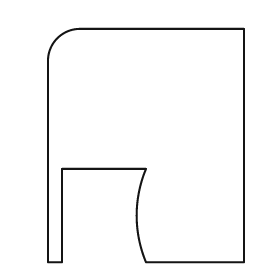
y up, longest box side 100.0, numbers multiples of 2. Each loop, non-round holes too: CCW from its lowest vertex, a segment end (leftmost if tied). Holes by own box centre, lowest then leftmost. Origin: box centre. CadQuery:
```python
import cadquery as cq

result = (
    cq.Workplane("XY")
    .moveTo(-42.0, -50.0)
    .lineTo(-36.0, -50.0)
    .lineTo(-36.0, -10.0)
    .lineTo(0.0, -10.0)
    .threePointArc((-4.0, -30.0), (0.0, -50.0))
    .lineTo(42.0, -50.0)
    .lineTo(42.0, 50.0)
    .lineTo(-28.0, 50.0)
    .threePointArc((-38.0, 46.0), (-42.0, 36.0))
    .close()
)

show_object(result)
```